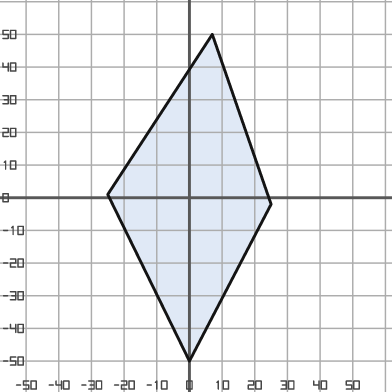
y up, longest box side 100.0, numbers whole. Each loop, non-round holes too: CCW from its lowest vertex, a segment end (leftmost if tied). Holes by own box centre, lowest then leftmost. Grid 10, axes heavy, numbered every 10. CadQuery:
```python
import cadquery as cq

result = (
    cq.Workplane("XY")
    .moveTo(0.0, -50.0)
    .lineTo(25.0, -2.0)
    .lineTo(7.0, 50.0)
    .lineTo(-25.0, 1.0)
    .close()
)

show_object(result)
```